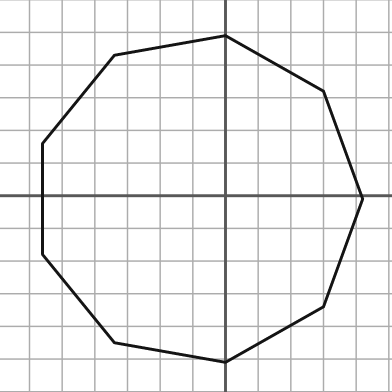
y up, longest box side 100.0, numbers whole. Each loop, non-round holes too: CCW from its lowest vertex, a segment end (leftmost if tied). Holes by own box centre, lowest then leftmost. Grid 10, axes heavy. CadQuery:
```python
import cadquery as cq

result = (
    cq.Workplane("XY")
    .moveTo(0.0, -51.0)
    .lineTo(30.0, -34.0)
    .lineTo(42.0, -1.0)
    .lineTo(30.0, 32.0)
    .lineTo(0.0, 49.0)
    .lineTo(-34.0, 43.0)
    .lineTo(-56.0, 16.0)
    .lineTo(-56.0, -18.0)
    .lineTo(-34.0, -45.0)
    .close()
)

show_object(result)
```